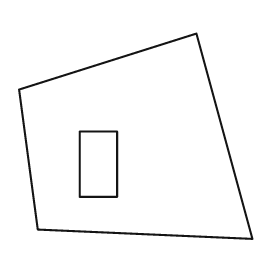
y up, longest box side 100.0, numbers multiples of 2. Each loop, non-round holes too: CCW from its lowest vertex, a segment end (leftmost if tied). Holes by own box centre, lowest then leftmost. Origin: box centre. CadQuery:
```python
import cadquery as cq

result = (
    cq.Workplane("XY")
    .moveTo(50.0, -44.0)
    .lineTo(26.0, 44.0)
    .lineTo(-50.0, 20.0)
    .lineTo(-42.0, -40.0)
    .close()
    .moveTo(-24.0, -26.0)
    .lineTo(-8.0, -26.0)
    .lineTo(-8.0, 2.0)
    .lineTo(-24.0, 2.0)
    .close()
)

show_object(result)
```